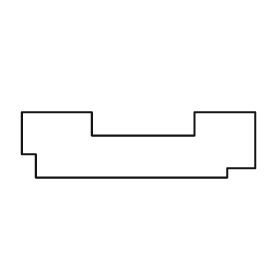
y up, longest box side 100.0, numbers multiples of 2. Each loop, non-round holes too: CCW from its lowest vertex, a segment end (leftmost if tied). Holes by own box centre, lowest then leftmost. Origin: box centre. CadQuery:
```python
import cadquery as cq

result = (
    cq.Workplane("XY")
    .moveTo(-44.0, -14.0)
    .lineTo(38.0, -14.0)
    .lineTo(38.0, -10.0)
    .lineTo(50.0, -10.0)
    .lineTo(50.0, 14.0)
    .lineTo(24.0, 14.0)
    .lineTo(24.0, 4.0)
    .lineTo(-20.0, 4.0)
    .lineTo(-20.0, 14.0)
    .lineTo(-50.0, 14.0)
    .lineTo(-50.0, -4.0)
    .lineTo(-44.0, -4.0)
    .close()
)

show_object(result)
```